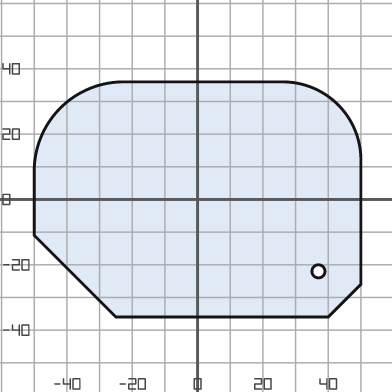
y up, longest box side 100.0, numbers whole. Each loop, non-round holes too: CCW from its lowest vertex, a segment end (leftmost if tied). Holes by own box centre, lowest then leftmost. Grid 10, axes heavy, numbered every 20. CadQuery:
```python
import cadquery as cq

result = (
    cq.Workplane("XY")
    .moveTo(-25.0, -36.0)
    .lineTo(40.0, -36.0)
    .lineTo(50.0, -26.0)
    .lineTo(50.0, 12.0)
    .threePointArc((43.0, 29.0), (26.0, 36.0))
    .lineTo(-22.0, 36.0)
    .threePointArc((-42.0, 28.0), (-50.0, 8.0))
    .lineTo(-50.0, -11.0)
    .close()
    .moveTo(37.0, -22.0)
    .circle(2.0)
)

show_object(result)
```